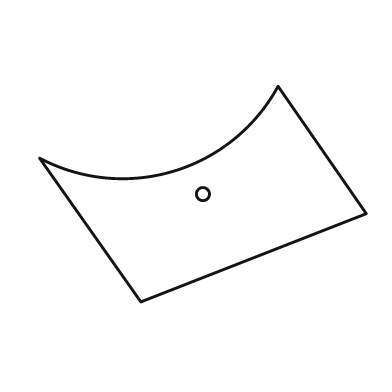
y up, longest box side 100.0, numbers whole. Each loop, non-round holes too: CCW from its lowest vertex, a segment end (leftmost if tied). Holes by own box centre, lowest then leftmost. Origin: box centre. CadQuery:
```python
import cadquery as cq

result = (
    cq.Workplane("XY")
    .moveTo(-19.0, -33.0)
    .lineTo(50.0, -6.0)
    .lineTo(23.0, 33.0)
    .threePointArc((-9.0, 7.0), (-50.0, 11.0))
    .close()
    .moveTo(0.0, 0.0)
    .circle(2.0)
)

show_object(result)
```